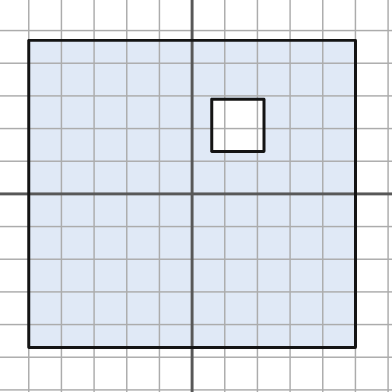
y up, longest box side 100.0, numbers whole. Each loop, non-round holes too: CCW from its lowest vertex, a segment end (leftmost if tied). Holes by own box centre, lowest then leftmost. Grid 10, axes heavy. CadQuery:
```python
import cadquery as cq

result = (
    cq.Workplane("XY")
    .moveTo(-50.0, -47.0)
    .lineTo(50.0, -47.0)
    .lineTo(50.0, 47.0)
    .lineTo(-50.0, 47.0)
    .close()
    .moveTo(6.0, 13.0)
    .lineTo(22.0, 13.0)
    .lineTo(22.0, 29.0)
    .lineTo(6.0, 29.0)
    .close()
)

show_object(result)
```